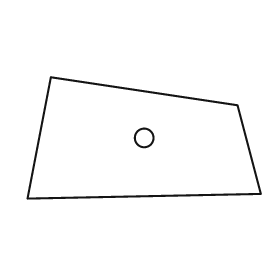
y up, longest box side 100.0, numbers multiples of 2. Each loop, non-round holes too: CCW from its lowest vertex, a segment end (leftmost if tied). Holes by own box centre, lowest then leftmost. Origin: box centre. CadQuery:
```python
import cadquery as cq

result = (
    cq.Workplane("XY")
    .moveTo(-50.0, -26.0)
    .lineTo(50.0, -24.0)
    .lineTo(40.0, 14.0)
    .lineTo(-40.0, 26.0)
    .close()
    .moveTo(0.0, 0.0)
    .circle(4.0)
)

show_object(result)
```